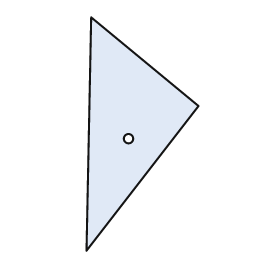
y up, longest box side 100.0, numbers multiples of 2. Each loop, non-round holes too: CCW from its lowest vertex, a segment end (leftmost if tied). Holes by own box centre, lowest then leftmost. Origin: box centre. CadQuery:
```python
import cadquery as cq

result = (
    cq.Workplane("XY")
    .moveTo(-24.0, -50.0)
    .lineTo(24.0, 12.0)
    .lineTo(-22.0, 50.0)
    .close()
    .moveTo(-6.0, -2.0)
    .circle(2.0)
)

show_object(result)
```